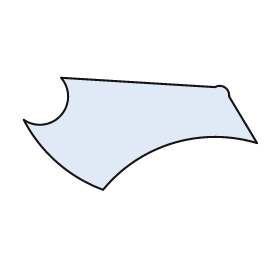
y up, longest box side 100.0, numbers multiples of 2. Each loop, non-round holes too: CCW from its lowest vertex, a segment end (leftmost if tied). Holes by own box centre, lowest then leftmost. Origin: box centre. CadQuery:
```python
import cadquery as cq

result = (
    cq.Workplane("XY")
    .moveTo(-16.0, -24.0)
    .threePointArc((14.0, -4.0), (50.0, -4.0))
    .lineTo(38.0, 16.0)
    .threePointArc((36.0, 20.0), (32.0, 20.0))
    .lineTo(-34.0, 24.0)
    .threePointArc((-34.0, 8.0), (-50.0, 6.0))
    .threePointArc((-36.0, -12.0), (-16.0, -24.0))
    .close()
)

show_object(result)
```